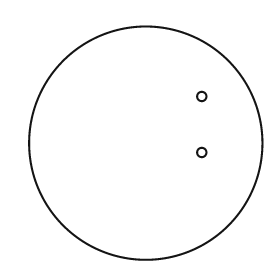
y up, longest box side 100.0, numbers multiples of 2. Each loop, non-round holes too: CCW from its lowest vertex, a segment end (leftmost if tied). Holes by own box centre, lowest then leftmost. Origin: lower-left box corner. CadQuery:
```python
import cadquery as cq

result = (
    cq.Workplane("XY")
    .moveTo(50.0, 50.0)
    .circle(50.0)
    .moveTo(74.0, 46.0)
    .circle(2.0)
    .moveTo(74.0, 70.0)
    .circle(2.0)
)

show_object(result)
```